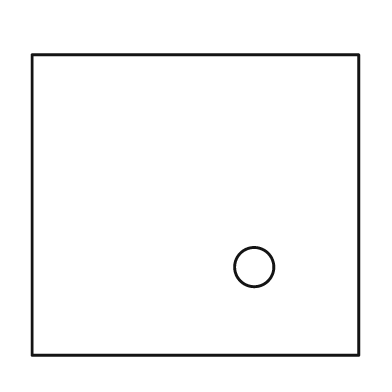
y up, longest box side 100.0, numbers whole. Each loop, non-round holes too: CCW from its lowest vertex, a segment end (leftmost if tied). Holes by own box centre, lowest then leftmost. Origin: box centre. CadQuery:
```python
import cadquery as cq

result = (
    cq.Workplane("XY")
    .moveTo(-50.0, -46.0)
    .lineTo(50.0, -46.0)
    .lineTo(50.0, 46.0)
    .lineTo(-50.0, 46.0)
    .close()
    .moveTo(18.0, -19.0)
    .circle(6.0)
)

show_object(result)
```